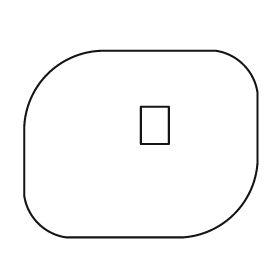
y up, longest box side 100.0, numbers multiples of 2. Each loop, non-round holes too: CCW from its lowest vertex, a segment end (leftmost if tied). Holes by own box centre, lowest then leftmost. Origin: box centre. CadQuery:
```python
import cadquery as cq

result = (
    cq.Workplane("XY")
    .moveTo(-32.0, -40.0)
    .lineTo(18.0, -40.0)
    .threePointArc((40.0, -30.0), (50.0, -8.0))
    .lineTo(50.0, 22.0)
    .threePointArc((44.0, 34.0), (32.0, 40.0))
    .lineTo(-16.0, 40.0)
    .threePointArc((-40.0, 30.0), (-50.0, 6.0))
    .lineTo(-50.0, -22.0)
    .threePointArc((-44.0, -34.0), (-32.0, -40.0))
    .close()
    .moveTo(0.0, 0.0)
    .lineTo(12.0, 0.0)
    .lineTo(12.0, 16.0)
    .lineTo(0.0, 16.0)
    .close()
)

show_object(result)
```